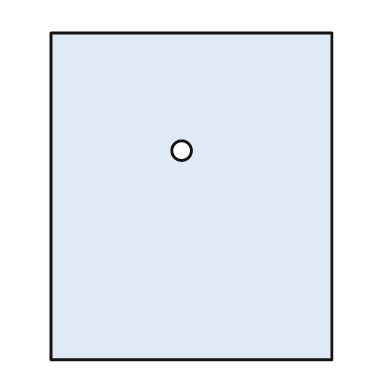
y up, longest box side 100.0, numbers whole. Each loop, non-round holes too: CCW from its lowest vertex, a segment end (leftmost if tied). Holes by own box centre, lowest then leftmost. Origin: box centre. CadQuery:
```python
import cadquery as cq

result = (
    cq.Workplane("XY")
    .moveTo(-43.0, -50.0)
    .lineTo(43.0, -50.0)
    .lineTo(43.0, 50.0)
    .lineTo(-43.0, 50.0)
    .close()
    .moveTo(-3.0, 14.0)
    .circle(3.0)
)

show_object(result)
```